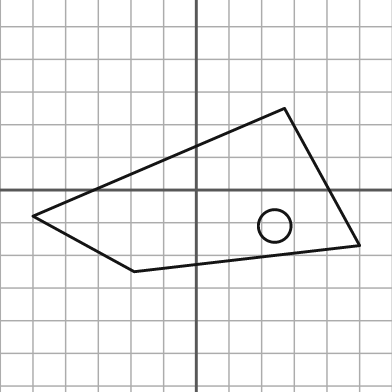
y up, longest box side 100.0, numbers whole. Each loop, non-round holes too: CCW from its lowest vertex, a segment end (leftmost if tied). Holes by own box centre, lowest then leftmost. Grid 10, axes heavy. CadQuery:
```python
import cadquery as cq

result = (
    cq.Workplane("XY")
    .moveTo(-19.0, -25.0)
    .lineTo(50.0, -17.0)
    .lineTo(27.0, 25.0)
    .lineTo(-50.0, -8.0)
    .close()
    .moveTo(24.0, -11.0)
    .circle(5.0)
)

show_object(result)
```